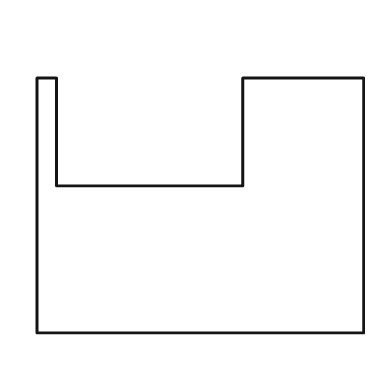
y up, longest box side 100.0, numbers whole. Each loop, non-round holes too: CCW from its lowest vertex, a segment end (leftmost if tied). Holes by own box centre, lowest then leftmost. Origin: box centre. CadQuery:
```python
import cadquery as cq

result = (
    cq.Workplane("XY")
    .moveTo(-50.0, -39.0)
    .lineTo(50.0, -39.0)
    .lineTo(50.0, 39.0)
    .lineTo(13.0, 39.0)
    .lineTo(13.0, 6.0)
    .lineTo(-44.0, 6.0)
    .lineTo(-44.0, 39.0)
    .lineTo(-50.0, 39.0)
    .close()
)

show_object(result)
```